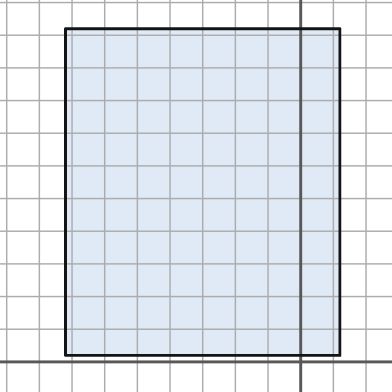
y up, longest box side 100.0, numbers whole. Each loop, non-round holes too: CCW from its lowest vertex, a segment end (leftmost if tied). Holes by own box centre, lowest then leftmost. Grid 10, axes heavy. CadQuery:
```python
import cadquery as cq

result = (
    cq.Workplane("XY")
    .moveTo(-72.0, 2.0)
    .lineTo(12.0, 2.0)
    .lineTo(12.0, 102.0)
    .lineTo(-72.0, 102.0)
    .close()
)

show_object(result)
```